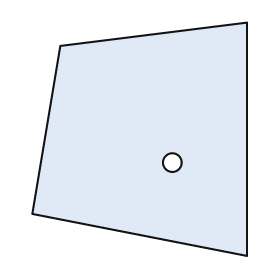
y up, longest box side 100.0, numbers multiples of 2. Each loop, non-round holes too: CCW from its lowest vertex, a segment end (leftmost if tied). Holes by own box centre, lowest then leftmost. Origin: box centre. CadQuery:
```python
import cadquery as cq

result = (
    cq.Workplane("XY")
    .moveTo(46.0, -50.0)
    .lineTo(46.0, 50.0)
    .lineTo(-34.0, 40.0)
    .lineTo(-46.0, -32.0)
    .close()
    .moveTo(14.0, -10.0)
    .circle(4.0)
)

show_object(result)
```